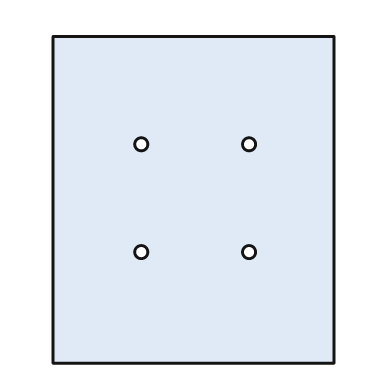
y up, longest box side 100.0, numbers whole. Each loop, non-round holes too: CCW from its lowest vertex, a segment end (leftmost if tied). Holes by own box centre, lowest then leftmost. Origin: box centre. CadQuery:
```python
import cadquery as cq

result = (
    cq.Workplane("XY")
    .moveTo(-43.0, -50.0)
    .lineTo(43.0, -50.0)
    .lineTo(43.0, 50.0)
    .lineTo(-43.0, 50.0)
    .close()
    .moveTo(-16.0, -16.0)
    .circle(2.0)
    .moveTo(17.0, -16.0)
    .circle(2.0)
    .moveTo(-16.0, 17.0)
    .circle(2.0)
    .moveTo(17.0, 17.0)
    .circle(2.0)
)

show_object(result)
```